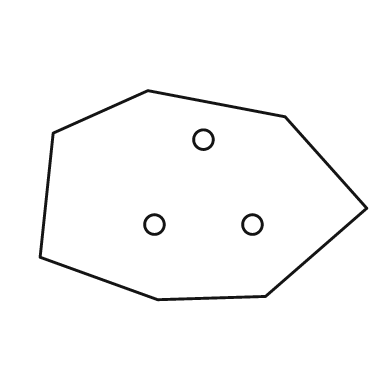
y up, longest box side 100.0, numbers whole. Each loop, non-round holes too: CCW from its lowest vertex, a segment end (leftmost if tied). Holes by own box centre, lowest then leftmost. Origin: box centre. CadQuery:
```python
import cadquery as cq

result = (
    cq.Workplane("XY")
    .moveTo(-14.0, -32.0)
    .lineTo(19.0, -31.0)
    .lineTo(50.0, -4.0)
    .lineTo(25.0, 24.0)
    .lineTo(-17.0, 32.0)
    .lineTo(-46.0, 19.0)
    .lineTo(-50.0, -19.0)
    .close()
    .moveTo(-15.0, -9.0)
    .circle(3.0)
    .moveTo(15.0, -9.0)
    .circle(3.0)
    .moveTo(0.0, 17.0)
    .circle(3.0)
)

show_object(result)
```